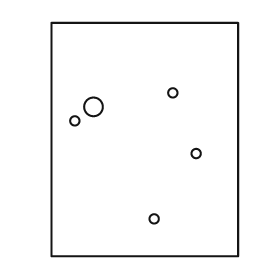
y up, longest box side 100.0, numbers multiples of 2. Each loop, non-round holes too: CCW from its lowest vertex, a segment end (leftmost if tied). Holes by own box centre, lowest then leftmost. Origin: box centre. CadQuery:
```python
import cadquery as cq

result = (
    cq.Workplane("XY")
    .moveTo(-40.0, -50.0)
    .lineTo(40.0, -50.0)
    .lineTo(40.0, 50.0)
    .lineTo(-40.0, 50.0)
    .close()
    .moveTo(4.0, -34.0)
    .circle(2.0)
    .moveTo(22.0, -6.0)
    .circle(2.0)
    .moveTo(-30.0, 8.0)
    .circle(2.0)
    .moveTo(-22.0, 14.0)
    .circle(4.0)
    .moveTo(12.0, 20.0)
    .circle(2.0)
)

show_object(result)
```